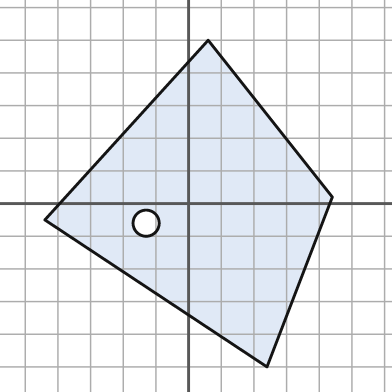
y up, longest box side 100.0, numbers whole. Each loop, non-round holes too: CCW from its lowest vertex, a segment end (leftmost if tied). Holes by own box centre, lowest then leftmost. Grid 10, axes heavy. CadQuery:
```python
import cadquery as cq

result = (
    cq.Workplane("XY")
    .moveTo(24.0, -50.0)
    .lineTo(44.0, 2.0)
    .lineTo(6.0, 50.0)
    .lineTo(-44.0, -5.0)
    .close()
    .moveTo(-13.0, -6.0)
    .circle(4.0)
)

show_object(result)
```